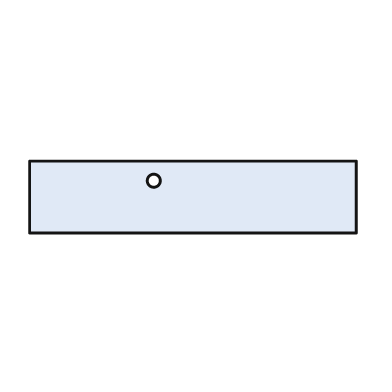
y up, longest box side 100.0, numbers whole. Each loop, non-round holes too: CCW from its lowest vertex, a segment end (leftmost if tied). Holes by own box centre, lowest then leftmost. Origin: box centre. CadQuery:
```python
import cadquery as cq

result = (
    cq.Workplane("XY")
    .moveTo(-50.0, -11.0)
    .lineTo(50.0, -11.0)
    .lineTo(50.0, 11.0)
    .lineTo(-50.0, 11.0)
    .close()
    .moveTo(-12.0, 5.0)
    .circle(2.0)
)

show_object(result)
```